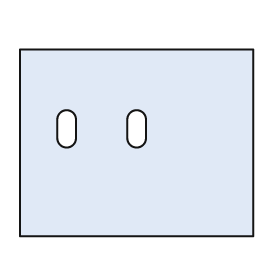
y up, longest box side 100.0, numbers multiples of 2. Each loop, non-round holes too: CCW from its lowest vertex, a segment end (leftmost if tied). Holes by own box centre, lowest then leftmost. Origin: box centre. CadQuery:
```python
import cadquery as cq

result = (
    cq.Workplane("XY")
    .moveTo(-50.0, -40.0)
    .lineTo(50.0, -40.0)
    .lineTo(50.0, 40.0)
    .lineTo(-50.0, 40.0)
    .close()
    .moveTo(-34.0, 2.0)
    .threePointArc((-30.0, -2.0), (-26.0, 2.0))
    .lineTo(-26.0, 10.0)
    .threePointArc((-30.0, 14.0), (-34.0, 10.0))
    .close()
    .moveTo(-4.0, 2.0)
    .threePointArc((0.0, -2.0), (4.0, 2.0))
    .lineTo(4.0, 10.0)
    .threePointArc((0.0, 14.0), (-4.0, 10.0))
    .close()
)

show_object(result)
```